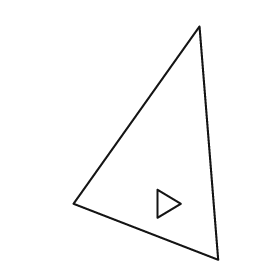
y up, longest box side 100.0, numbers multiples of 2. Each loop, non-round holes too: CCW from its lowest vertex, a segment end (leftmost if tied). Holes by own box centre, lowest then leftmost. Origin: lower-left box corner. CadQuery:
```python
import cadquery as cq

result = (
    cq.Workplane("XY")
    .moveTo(62.0, 0.0)
    .lineTo(54.0, 100.0)
    .lineTo(0.0, 24.0)
    .close()
    .moveTo(36.0, 18.0)
    .lineTo(46.0, 24.0)
    .lineTo(36.0, 30.0)
    .close()
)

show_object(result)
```